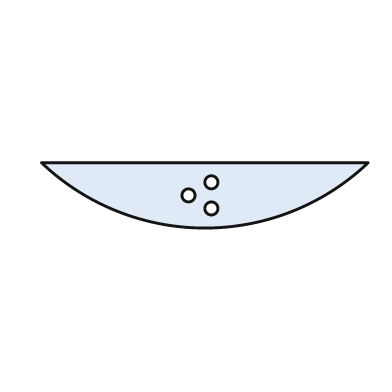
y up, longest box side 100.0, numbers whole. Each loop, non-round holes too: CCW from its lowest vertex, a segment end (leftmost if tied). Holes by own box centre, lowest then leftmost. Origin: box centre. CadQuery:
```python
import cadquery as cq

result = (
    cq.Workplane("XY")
    .moveTo(-50.0, 10.0)
    .threePointArc((0.0, -10.0), (50.0, 10.0))
    .close()
    .moveTo(2.0, -4.0)
    .circle(2.0)
    .moveTo(-5.0, 0.0)
    .circle(2.0)
    .moveTo(2.0, 4.0)
    .circle(2.0)
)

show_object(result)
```